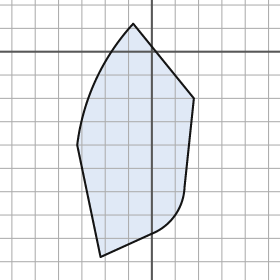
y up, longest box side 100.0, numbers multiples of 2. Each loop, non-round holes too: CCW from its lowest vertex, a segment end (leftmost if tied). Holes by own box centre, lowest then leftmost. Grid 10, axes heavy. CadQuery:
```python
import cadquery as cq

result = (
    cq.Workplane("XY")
    .moveTo(-22.0, -88.0)
    .lineTo(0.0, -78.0)
    .threePointArc((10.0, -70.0), (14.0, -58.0))
    .lineTo(18.0, -20.0)
    .lineTo(-8.0, 12.0)
    .threePointArc((-24.0, -12.0), (-32.0, -40.0))
    .close()
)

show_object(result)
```